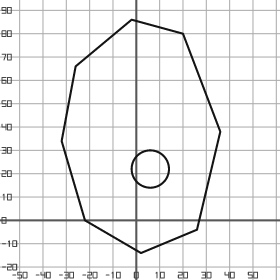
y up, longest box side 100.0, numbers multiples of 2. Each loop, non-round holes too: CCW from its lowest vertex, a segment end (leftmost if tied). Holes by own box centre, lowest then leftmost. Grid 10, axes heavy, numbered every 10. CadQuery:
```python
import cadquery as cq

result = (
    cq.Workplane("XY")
    .moveTo(2.0, -14.0)
    .lineTo(26.0, -4.0)
    .lineTo(36.0, 38.0)
    .lineTo(20.0, 80.0)
    .lineTo(-2.0, 86.0)
    .lineTo(-26.0, 66.0)
    .lineTo(-32.0, 34.0)
    .lineTo(-22.0, 0.0)
    .close()
    .moveTo(6.0, 22.0)
    .circle(8.0)
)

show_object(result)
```